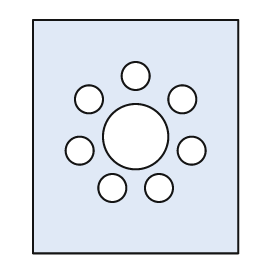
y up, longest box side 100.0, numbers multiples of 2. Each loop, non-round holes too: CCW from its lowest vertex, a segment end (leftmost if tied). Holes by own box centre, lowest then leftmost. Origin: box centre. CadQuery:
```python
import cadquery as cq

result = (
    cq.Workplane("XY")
    .moveTo(-44.0, -50.0)
    .lineTo(44.0, -50.0)
    .lineTo(44.0, 50.0)
    .lineTo(-44.0, 50.0)
    .close()
    .moveTo(-10.0, -22.0)
    .circle(6.0)
    .moveTo(10.0, -22.0)
    .circle(6.0)
    .moveTo(-24.0, -6.0)
    .circle(6.0)
    .moveTo(24.0, -6.0)
    .circle(6.0)
    .moveTo(0.0, 0.0)
    .circle(14.0)
    .moveTo(-20.0, 16.0)
    .circle(6.0)
    .moveTo(20.0, 16.0)
    .circle(6.0)
    .moveTo(0.0, 26.0)
    .circle(6.0)
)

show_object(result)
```